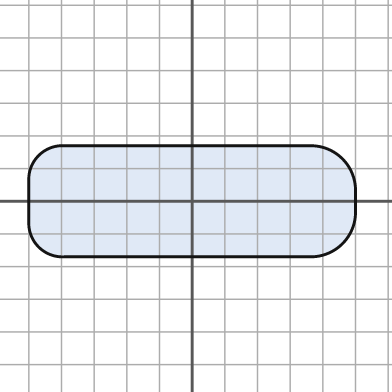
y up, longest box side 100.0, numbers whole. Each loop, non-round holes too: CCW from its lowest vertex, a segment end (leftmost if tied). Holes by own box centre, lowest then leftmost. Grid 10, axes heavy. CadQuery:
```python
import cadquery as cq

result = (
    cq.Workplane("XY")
    .moveTo(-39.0, -17.0)
    .lineTo(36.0, -17.0)
    .threePointArc((46.0, -13.0), (50.0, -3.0))
    .lineTo(50.0, 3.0)
    .threePointArc((46.0, 13.0), (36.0, 17.0))
    .lineTo(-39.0, 17.0)
    .threePointArc((-47.0, 14.0), (-50.0, 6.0))
    .lineTo(-50.0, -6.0)
    .threePointArc((-47.0, -14.0), (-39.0, -17.0))
    .close()
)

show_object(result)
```